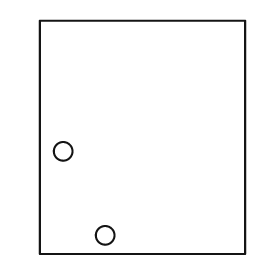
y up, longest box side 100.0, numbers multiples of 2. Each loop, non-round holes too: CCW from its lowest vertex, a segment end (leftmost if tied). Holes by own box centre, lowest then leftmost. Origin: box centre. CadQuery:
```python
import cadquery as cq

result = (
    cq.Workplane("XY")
    .moveTo(-44.0, -50.0)
    .lineTo(44.0, -50.0)
    .lineTo(44.0, 50.0)
    .lineTo(-44.0, 50.0)
    .close()
    .moveTo(-16.0, -42.0)
    .circle(4.0)
    .moveTo(-34.0, -6.0)
    .circle(4.0)
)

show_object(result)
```